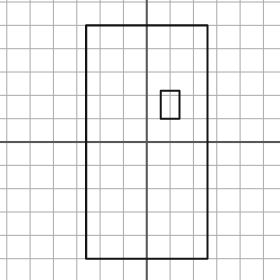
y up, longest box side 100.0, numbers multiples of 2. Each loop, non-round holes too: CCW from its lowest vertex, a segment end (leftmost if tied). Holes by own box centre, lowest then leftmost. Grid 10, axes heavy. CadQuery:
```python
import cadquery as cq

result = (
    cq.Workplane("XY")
    .moveTo(-26.0, -50.0)
    .lineTo(26.0, -50.0)
    .lineTo(26.0, 50.0)
    .lineTo(-26.0, 50.0)
    .close()
    .moveTo(6.0, 10.0)
    .lineTo(14.0, 10.0)
    .lineTo(14.0, 22.0)
    .lineTo(6.0, 22.0)
    .close()
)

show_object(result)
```